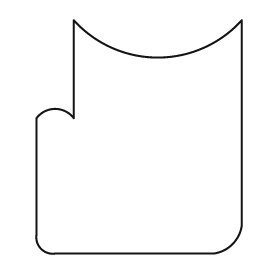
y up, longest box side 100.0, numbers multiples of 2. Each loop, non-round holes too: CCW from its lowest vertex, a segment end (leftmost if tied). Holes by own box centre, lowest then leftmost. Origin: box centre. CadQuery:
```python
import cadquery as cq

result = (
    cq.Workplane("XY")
    .moveTo(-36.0, -50.0)
    .lineTo(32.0, -50.0)
    .threePointArc((40.0, -46.0), (44.0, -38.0))
    .lineTo(44.0, 50.0)
    .threePointArc((8.0, 34.0), (-28.0, 50.0))
    .lineTo(-28.0, 8.0)
    .threePointArc((-36.0, 12.0), (-44.0, 8.0))
    .lineTo(-44.0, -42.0)
    .threePointArc((-42.0, -48.0), (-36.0, -50.0))
    .close()
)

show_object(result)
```